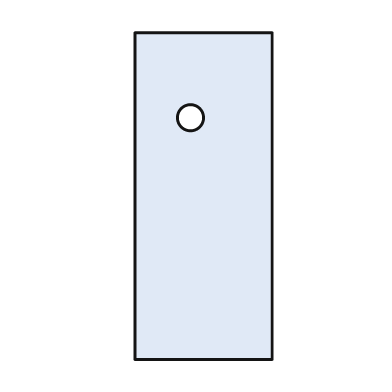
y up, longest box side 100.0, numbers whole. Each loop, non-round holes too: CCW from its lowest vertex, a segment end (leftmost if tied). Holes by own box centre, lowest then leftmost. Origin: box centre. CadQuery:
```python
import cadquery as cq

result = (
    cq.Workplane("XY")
    .moveTo(-21.0, -50.0)
    .lineTo(21.0, -50.0)
    .lineTo(21.0, 50.0)
    .lineTo(-21.0, 50.0)
    .close()
    .moveTo(-4.0, 24.0)
    .circle(4.0)
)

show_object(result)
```